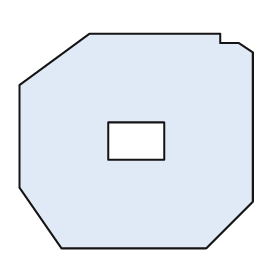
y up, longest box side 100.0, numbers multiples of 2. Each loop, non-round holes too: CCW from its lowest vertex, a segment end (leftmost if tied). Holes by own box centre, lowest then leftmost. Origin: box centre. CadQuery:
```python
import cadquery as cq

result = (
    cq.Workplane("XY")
    .moveTo(-32.0, -46.0)
    .lineTo(30.0, -46.0)
    .lineTo(50.0, -26.0)
    .lineTo(50.0, 38.0)
    .lineTo(44.0, 42.0)
    .lineTo(36.0, 42.0)
    .lineTo(36.0, 46.0)
    .lineTo(-20.0, 46.0)
    .lineTo(-50.0, 24.0)
    .lineTo(-50.0, -20.0)
    .close()
    .moveTo(-12.0, -8.0)
    .lineTo(12.0, -8.0)
    .lineTo(12.0, 8.0)
    .lineTo(-12.0, 8.0)
    .close()
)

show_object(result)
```